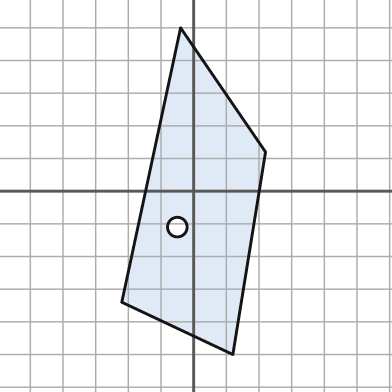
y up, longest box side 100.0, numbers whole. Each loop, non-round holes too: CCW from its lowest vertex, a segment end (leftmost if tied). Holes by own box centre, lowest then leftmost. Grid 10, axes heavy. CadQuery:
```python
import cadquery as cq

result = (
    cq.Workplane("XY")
    .moveTo(12.0, -50.0)
    .lineTo(22.0, 12.0)
    .lineTo(-4.0, 50.0)
    .lineTo(-22.0, -34.0)
    .close()
    .moveTo(-5.0, -11.0)
    .circle(3.0)
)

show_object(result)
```